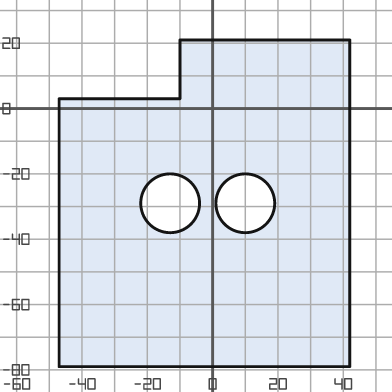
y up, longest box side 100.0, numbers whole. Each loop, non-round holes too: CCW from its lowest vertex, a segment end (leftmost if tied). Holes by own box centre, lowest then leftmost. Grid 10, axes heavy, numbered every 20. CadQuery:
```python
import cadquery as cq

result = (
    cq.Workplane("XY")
    .moveTo(-47.0, -79.0)
    .lineTo(42.0, -79.0)
    .lineTo(42.0, 21.0)
    .lineTo(-10.0, 21.0)
    .lineTo(-10.0, 3.0)
    .lineTo(-47.0, 3.0)
    .close()
    .moveTo(-13.0, -29.0)
    .circle(9.0)
    .moveTo(10.0, -29.0)
    .circle(9.0)
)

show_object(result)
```